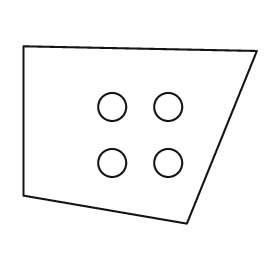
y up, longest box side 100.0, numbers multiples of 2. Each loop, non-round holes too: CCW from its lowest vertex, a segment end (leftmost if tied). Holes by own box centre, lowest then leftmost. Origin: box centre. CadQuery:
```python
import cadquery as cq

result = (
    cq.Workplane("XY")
    .moveTo(20.0, -38.0)
    .lineTo(50.0, 36.0)
    .lineTo(-50.0, 38.0)
    .lineTo(-50.0, -26.0)
    .close()
    .moveTo(-12.0, -12.0)
    .circle(6.0)
    .moveTo(12.0, -12.0)
    .circle(6.0)
    .moveTo(-12.0, 12.0)
    .circle(6.0)
    .moveTo(12.0, 12.0)
    .circle(6.0)
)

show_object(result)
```